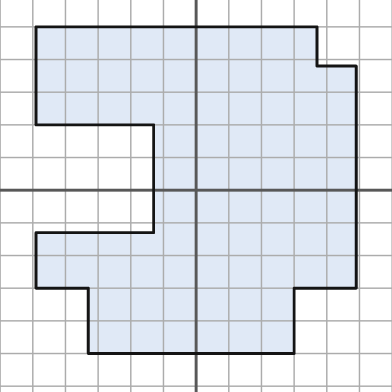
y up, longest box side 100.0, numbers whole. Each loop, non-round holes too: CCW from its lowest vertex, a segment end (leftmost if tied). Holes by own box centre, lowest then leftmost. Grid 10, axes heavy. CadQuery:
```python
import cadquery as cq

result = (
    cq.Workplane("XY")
    .moveTo(-33.0, -50.0)
    .lineTo(30.0, -50.0)
    .lineTo(30.0, -30.0)
    .lineTo(49.0, -30.0)
    .lineTo(49.0, 38.0)
    .lineTo(37.0, 38.0)
    .lineTo(37.0, 50.0)
    .lineTo(-49.0, 50.0)
    .lineTo(-49.0, 20.0)
    .lineTo(-13.0, 20.0)
    .lineTo(-13.0, -13.0)
    .lineTo(-49.0, -13.0)
    .lineTo(-49.0, -30.0)
    .lineTo(-33.0, -30.0)
    .close()
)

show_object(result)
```